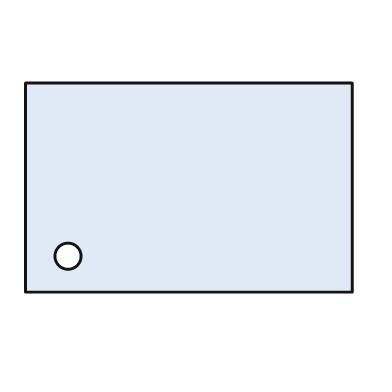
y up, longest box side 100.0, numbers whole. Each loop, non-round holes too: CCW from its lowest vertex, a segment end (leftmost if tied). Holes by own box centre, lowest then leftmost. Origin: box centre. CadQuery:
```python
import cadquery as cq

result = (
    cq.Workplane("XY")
    .moveTo(-50.0, -32.0)
    .lineTo(50.0, -32.0)
    .lineTo(50.0, 32.0)
    .lineTo(-50.0, 32.0)
    .close()
    .moveTo(-37.0, -21.0)
    .circle(4.0)
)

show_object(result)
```